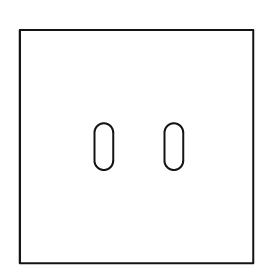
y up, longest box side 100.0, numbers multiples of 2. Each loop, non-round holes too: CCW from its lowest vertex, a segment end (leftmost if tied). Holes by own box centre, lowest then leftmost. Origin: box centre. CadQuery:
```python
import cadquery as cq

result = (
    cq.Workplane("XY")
    .moveTo(-50.0, -50.0)
    .lineTo(50.0, -50.0)
    .lineTo(50.0, 50.0)
    .lineTo(-50.0, 50.0)
    .close()
    .moveTo(-18.0, -6.0)
    .threePointArc((-14.0, -10.0), (-10.0, -6.0))
    .lineTo(-10.0, 6.0)
    .threePointArc((-14.0, 10.0), (-18.0, 6.0))
    .close()
    .moveTo(12.0, -6.0)
    .threePointArc((16.0, -10.0), (20.0, -6.0))
    .lineTo(20.0, 6.0)
    .threePointArc((16.0, 10.0), (12.0, 6.0))
    .close()
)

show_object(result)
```